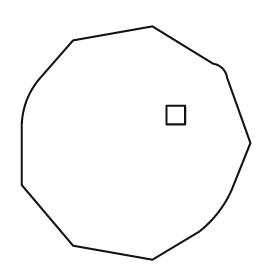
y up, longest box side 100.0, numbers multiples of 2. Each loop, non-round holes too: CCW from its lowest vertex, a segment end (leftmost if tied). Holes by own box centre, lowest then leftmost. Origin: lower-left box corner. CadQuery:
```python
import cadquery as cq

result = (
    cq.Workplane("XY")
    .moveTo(56.0, 0.0)
    .lineTo(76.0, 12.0)
    .threePointArc((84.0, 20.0), (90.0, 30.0))
    .lineTo(98.0, 50.0)
    .lineTo(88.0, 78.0)
    .threePointArc((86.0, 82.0), (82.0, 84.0))
    .lineTo(56.0, 100.0)
    .lineTo(22.0, 94.0)
    .lineTo(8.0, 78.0)
    .threePointArc((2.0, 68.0), (0.0, 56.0))
    .lineTo(0.0, 32.0)
    .lineTo(22.0, 6.0)
    .close()
    .moveTo(62.0, 58.0)
    .lineTo(70.0, 58.0)
    .lineTo(70.0, 66.0)
    .lineTo(62.0, 66.0)
    .close()
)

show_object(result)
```